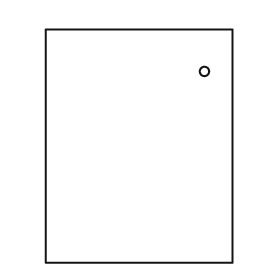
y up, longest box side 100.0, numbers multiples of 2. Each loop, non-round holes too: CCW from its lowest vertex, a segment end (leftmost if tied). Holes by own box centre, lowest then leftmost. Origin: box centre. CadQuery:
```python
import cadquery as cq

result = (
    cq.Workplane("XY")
    .moveTo(-40.0, -50.0)
    .lineTo(40.0, -50.0)
    .lineTo(40.0, 50.0)
    .lineTo(-40.0, 50.0)
    .close()
    .moveTo(28.0, 32.0)
    .circle(2.0)
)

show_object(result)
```